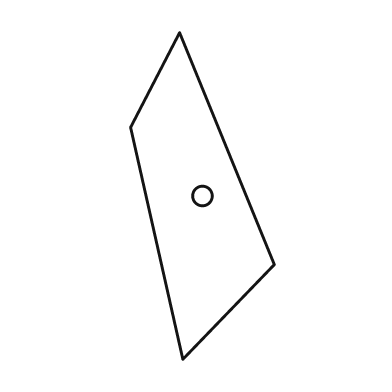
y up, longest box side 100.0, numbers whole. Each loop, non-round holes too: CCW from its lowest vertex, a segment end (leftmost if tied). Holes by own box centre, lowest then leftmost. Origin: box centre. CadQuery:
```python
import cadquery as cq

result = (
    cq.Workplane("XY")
    .moveTo(-6.0, -50.0)
    .lineTo(22.0, -21.0)
    .lineTo(-7.0, 50.0)
    .lineTo(-22.0, 21.0)
    .close()
    .moveTo(0.0, 0.0)
    .circle(3.0)
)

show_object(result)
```